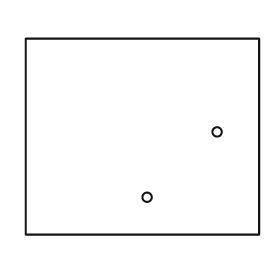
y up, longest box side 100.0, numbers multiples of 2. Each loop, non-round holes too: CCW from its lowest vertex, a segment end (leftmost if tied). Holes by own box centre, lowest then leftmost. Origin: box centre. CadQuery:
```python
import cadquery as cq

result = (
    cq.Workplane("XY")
    .moveTo(-50.0, -42.0)
    .lineTo(50.0, -42.0)
    .lineTo(50.0, 42.0)
    .lineTo(-50.0, 42.0)
    .close()
    .moveTo(2.0, -26.0)
    .circle(2.0)
    .moveTo(32.0, 2.0)
    .circle(2.0)
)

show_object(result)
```